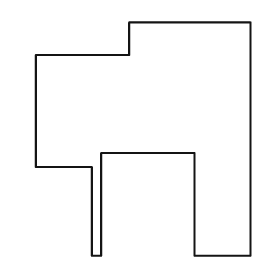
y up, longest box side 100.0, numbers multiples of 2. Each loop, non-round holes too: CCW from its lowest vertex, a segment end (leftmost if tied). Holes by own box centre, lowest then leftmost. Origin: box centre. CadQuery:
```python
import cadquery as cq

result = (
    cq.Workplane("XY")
    .moveTo(-22.0, -50.0)
    .lineTo(-18.0, -50.0)
    .lineTo(-18.0, -6.0)
    .lineTo(22.0, -6.0)
    .lineTo(22.0, -50.0)
    .lineTo(46.0, -50.0)
    .lineTo(46.0, 50.0)
    .lineTo(-6.0, 50.0)
    .lineTo(-6.0, 36.0)
    .lineTo(-46.0, 36.0)
    .lineTo(-46.0, -12.0)
    .lineTo(-22.0, -12.0)
    .close()
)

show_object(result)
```